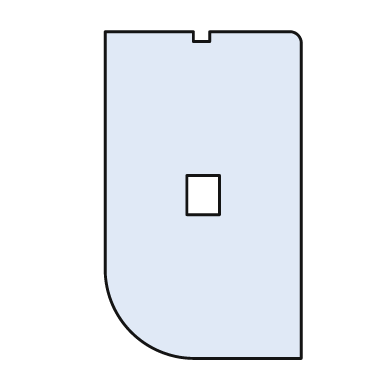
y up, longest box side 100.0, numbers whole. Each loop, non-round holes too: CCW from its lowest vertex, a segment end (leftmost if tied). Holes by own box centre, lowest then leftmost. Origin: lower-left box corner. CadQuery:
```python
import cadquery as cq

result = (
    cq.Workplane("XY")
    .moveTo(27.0, 0.0)
    .lineTo(60.0, 0.0)
    .lineTo(60.0, 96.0)
    .threePointArc((59.0, 99.0), (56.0, 100.0))
    .lineTo(32.0, 100.0)
    .lineTo(32.0, 97.0)
    .lineTo(27.0, 97.0)
    .lineTo(27.0, 100.0)
    .lineTo(0.0, 100.0)
    .lineTo(0.0, 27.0)
    .threePointArc((8.0, 8.0), (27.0, 0.0))
    .close()
    .moveTo(25.0, 44.0)
    .lineTo(35.0, 44.0)
    .lineTo(35.0, 56.0)
    .lineTo(25.0, 56.0)
    .close()
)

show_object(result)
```